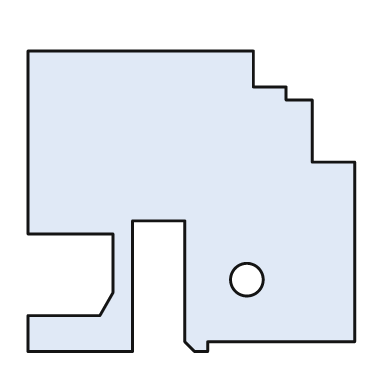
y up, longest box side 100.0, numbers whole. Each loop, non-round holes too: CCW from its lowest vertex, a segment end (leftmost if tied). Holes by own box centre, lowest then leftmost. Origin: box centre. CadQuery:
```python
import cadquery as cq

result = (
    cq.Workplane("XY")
    .moveTo(-50.0, -46.0)
    .lineTo(-18.0, -46.0)
    .lineTo(-18.0, -6.0)
    .lineTo(-2.0, -6.0)
    .lineTo(-2.0, -43.0)
    .lineTo(1.0, -46.0)
    .lineTo(5.0, -46.0)
    .lineTo(5.0, -43.0)
    .lineTo(50.0, -43.0)
    .lineTo(50.0, 12.0)
    .lineTo(37.0, 12.0)
    .lineTo(37.0, 31.0)
    .lineTo(29.0, 31.0)
    .lineTo(29.0, 35.0)
    .lineTo(19.0, 35.0)
    .lineTo(19.0, 46.0)
    .lineTo(-50.0, 46.0)
    .lineTo(-50.0, -10.0)
    .lineTo(-24.0, -10.0)
    .lineTo(-24.0, -28.0)
    .lineTo(-28.0, -35.0)
    .lineTo(-50.0, -35.0)
    .close()
    .moveTo(17.0, -24.0)
    .circle(5.0)
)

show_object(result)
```